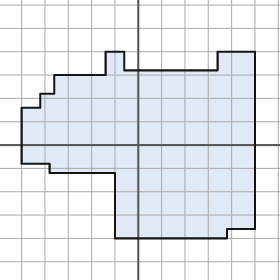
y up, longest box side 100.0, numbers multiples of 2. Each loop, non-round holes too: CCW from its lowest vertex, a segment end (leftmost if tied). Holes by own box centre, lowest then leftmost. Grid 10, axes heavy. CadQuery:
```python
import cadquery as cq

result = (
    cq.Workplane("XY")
    .moveTo(-10.0, -40.0)
    .lineTo(38.0, -40.0)
    .lineTo(38.0, -36.0)
    .lineTo(50.0, -36.0)
    .lineTo(50.0, 40.0)
    .lineTo(34.0, 40.0)
    .lineTo(34.0, 32.0)
    .lineTo(-6.0, 32.0)
    .lineTo(-6.0, 40.0)
    .lineTo(-14.0, 40.0)
    .lineTo(-14.0, 30.0)
    .lineTo(-36.0, 30.0)
    .lineTo(-36.0, 22.0)
    .lineTo(-42.0, 22.0)
    .lineTo(-42.0, 16.0)
    .lineTo(-50.0, 16.0)
    .lineTo(-50.0, -8.0)
    .lineTo(-38.0, -8.0)
    .lineTo(-38.0, -12.0)
    .lineTo(-10.0, -12.0)
    .close()
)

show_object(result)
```